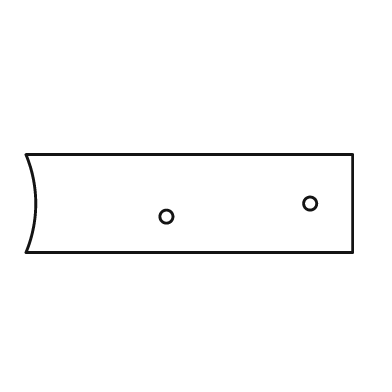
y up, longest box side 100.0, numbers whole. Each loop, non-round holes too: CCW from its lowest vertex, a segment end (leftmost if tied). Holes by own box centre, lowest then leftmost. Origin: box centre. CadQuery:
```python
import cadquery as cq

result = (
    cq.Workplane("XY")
    .moveTo(-50.0, -15.0)
    .lineTo(50.0, -15.0)
    .lineTo(50.0, 15.0)
    .lineTo(-50.0, 15.0)
    .threePointArc((-47.0, 0.0), (-50.0, -15.0))
    .close()
    .moveTo(-7.0, -4.0)
    .circle(2.0)
    .moveTo(37.0, 0.0)
    .circle(2.0)
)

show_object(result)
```